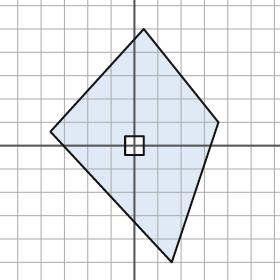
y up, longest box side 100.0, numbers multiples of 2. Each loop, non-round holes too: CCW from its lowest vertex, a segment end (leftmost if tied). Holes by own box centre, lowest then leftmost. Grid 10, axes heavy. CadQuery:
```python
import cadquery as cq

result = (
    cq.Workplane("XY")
    .moveTo(16.0, -50.0)
    .lineTo(36.0, 10.0)
    .lineTo(4.0, 50.0)
    .lineTo(-36.0, 6.0)
    .close()
    .moveTo(-4.0, -4.0)
    .lineTo(4.0, -4.0)
    .lineTo(4.0, 4.0)
    .lineTo(-4.0, 4.0)
    .close()
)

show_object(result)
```